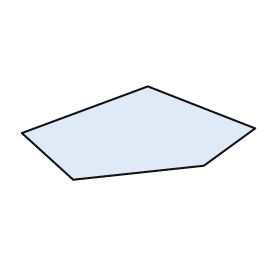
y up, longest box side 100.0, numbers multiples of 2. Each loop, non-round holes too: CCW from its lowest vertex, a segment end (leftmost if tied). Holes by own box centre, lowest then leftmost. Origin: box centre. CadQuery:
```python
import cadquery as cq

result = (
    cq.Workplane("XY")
    .moveTo(-28.0, -20.0)
    .lineTo(28.0, -14.0)
    .lineTo(50.0, 2.0)
    .lineTo(4.0, 20.0)
    .lineTo(-50.0, 0.0)
    .close()
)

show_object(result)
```